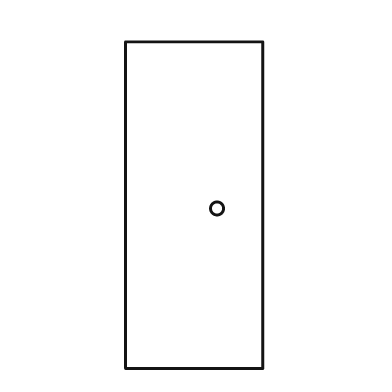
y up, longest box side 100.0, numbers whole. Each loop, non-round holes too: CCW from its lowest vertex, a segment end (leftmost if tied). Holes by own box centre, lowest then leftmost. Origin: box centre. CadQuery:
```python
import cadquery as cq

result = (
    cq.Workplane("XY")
    .moveTo(-21.0, -50.0)
    .lineTo(21.0, -50.0)
    .lineTo(21.0, 50.0)
    .lineTo(-21.0, 50.0)
    .close()
    .moveTo(7.0, -1.0)
    .circle(2.0)
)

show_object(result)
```